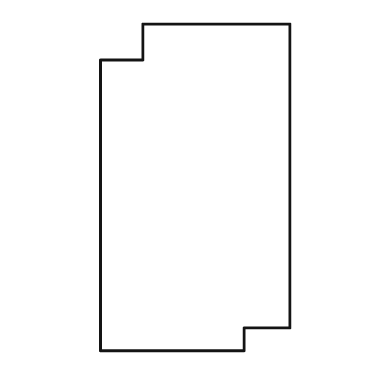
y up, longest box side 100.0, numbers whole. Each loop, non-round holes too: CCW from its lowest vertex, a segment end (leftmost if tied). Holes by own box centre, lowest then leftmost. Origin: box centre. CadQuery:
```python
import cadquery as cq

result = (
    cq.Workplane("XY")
    .moveTo(-29.0, -50.0)
    .lineTo(15.0, -50.0)
    .lineTo(15.0, -43.0)
    .lineTo(29.0, -43.0)
    .lineTo(29.0, 50.0)
    .lineTo(-16.0, 50.0)
    .lineTo(-16.0, 39.0)
    .lineTo(-29.0, 39.0)
    .close()
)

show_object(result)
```